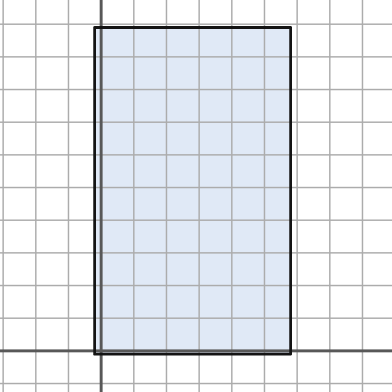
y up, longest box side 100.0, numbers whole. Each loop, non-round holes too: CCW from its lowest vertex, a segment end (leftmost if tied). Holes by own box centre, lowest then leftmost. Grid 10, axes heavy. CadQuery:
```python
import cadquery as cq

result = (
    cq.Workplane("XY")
    .moveTo(-2.0, -1.0)
    .lineTo(58.0, -1.0)
    .lineTo(58.0, 99.0)
    .lineTo(-2.0, 99.0)
    .close()
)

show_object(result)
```